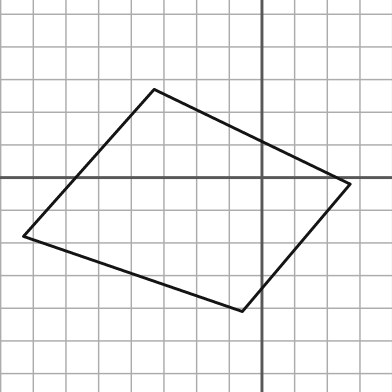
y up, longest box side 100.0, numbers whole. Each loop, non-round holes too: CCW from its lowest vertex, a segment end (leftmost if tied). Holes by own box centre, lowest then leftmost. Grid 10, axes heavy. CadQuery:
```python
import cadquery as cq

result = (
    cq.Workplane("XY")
    .moveTo(-6.0, -41.0)
    .lineTo(27.0, -2.0)
    .lineTo(-33.0, 27.0)
    .lineTo(-73.0, -18.0)
    .close()
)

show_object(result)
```